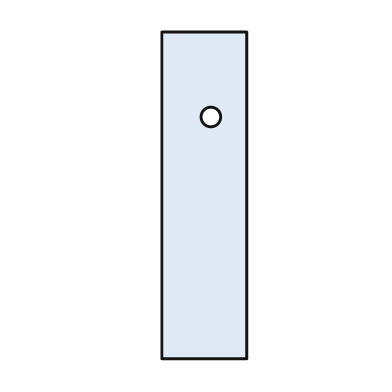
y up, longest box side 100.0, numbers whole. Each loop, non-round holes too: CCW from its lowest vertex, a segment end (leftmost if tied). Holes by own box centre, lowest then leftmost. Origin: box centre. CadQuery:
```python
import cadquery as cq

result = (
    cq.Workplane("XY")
    .moveTo(-13.0, -50.0)
    .lineTo(13.0, -50.0)
    .lineTo(13.0, 50.0)
    .lineTo(-13.0, 50.0)
    .close()
    .moveTo(2.0, 24.0)
    .circle(3.0)
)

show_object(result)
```